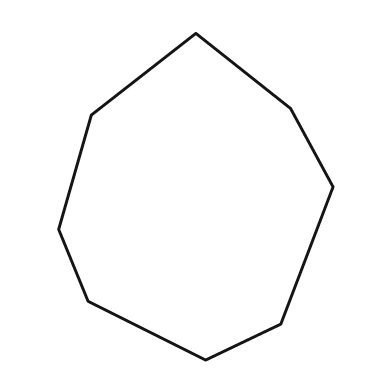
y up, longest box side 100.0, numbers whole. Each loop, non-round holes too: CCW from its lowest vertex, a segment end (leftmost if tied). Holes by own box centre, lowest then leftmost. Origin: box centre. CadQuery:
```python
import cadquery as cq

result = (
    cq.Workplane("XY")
    .moveTo(3.0, -50.0)
    .lineTo(26.0, -39.0)
    .lineTo(42.0, 3.0)
    .lineTo(29.0, 27.0)
    .lineTo(0.0, 50.0)
    .lineTo(-32.0, 25.0)
    .lineTo(-42.0, -10.0)
    .lineTo(-33.0, -32.0)
    .close()
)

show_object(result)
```